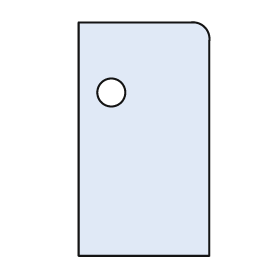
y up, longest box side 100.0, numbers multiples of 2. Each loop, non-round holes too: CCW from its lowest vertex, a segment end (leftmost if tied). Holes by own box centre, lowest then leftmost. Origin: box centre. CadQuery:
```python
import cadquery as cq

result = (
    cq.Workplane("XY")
    .moveTo(-28.0, -50.0)
    .lineTo(28.0, -50.0)
    .lineTo(28.0, 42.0)
    .threePointArc((26.0, 48.0), (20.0, 50.0))
    .lineTo(-28.0, 50.0)
    .close()
    .moveTo(-14.0, 20.0)
    .circle(6.0)
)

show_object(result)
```